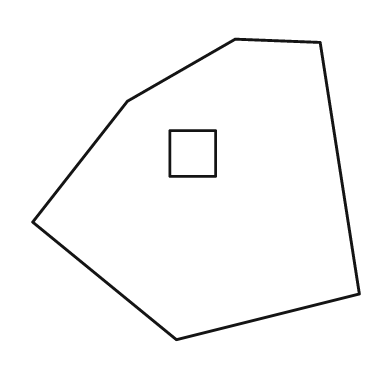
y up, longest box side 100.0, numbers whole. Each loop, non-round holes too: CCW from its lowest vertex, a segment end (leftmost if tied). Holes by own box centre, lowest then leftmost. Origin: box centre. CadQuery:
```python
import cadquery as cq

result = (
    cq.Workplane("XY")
    .moveTo(-6.0, -46.0)
    .lineTo(50.0, -32.0)
    .lineTo(38.0, 45.0)
    .lineTo(12.0, 46.0)
    .lineTo(-21.0, 27.0)
    .lineTo(-50.0, -10.0)
    .close()
    .moveTo(-8.0, 4.0)
    .lineTo(6.0, 4.0)
    .lineTo(6.0, 18.0)
    .lineTo(-8.0, 18.0)
    .close()
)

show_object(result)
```